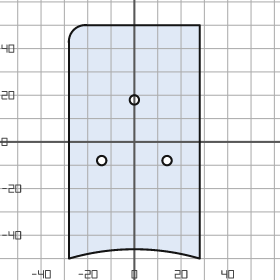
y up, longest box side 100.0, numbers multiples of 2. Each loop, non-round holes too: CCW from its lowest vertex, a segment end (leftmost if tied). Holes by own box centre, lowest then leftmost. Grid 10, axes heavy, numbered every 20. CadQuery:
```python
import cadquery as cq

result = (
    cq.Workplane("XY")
    .moveTo(-28.0, -50.0)
    .threePointArc((0.0, -46.0), (28.0, -50.0))
    .lineTo(28.0, 50.0)
    .lineTo(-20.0, 50.0)
    .threePointArc((-26.0, 48.0), (-28.0, 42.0))
    .close()
    .moveTo(-14.0, -8.0)
    .circle(2.0)
    .moveTo(14.0, -8.0)
    .circle(2.0)
    .moveTo(0.0, 18.0)
    .circle(2.0)
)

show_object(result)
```